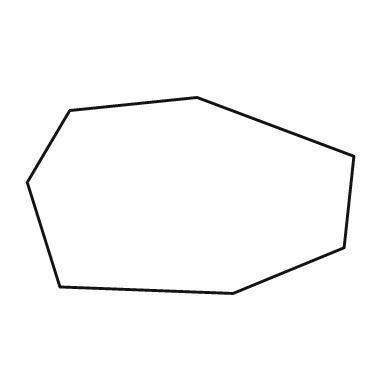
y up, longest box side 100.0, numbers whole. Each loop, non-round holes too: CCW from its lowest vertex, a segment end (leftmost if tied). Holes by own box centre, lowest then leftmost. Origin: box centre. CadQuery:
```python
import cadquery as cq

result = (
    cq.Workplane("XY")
    .moveTo(13.0, -30.0)
    .lineTo(47.0, -16.0)
    .lineTo(50.0, 12.0)
    .lineTo(2.0, 30.0)
    .lineTo(-37.0, 26.0)
    .lineTo(-50.0, 4.0)
    .lineTo(-40.0, -28.0)
    .close()
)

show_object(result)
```